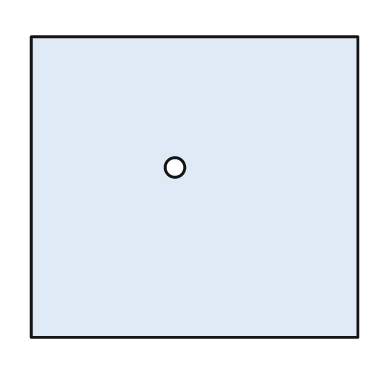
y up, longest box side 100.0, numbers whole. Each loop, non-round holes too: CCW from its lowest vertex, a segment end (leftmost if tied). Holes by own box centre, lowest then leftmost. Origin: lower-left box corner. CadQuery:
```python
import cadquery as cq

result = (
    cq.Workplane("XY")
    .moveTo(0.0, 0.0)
    .lineTo(100.0, 0.0)
    .lineTo(100.0, 92.0)
    .lineTo(0.0, 92.0)
    .close()
    .moveTo(44.0, 52.0)
    .circle(3.0)
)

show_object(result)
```